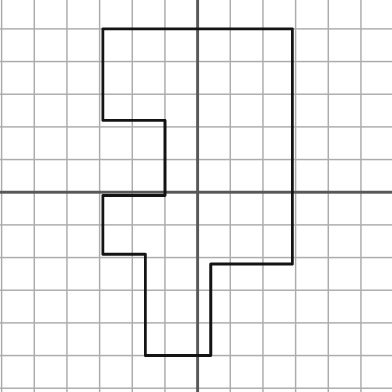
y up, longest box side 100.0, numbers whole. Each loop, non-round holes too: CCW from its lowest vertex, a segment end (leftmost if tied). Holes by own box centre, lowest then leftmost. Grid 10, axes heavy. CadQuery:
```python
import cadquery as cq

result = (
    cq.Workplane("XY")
    .moveTo(-16.0, -50.0)
    .lineTo(4.0, -50.0)
    .lineTo(4.0, -22.0)
    .lineTo(29.0, -22.0)
    .lineTo(29.0, 50.0)
    .lineTo(-29.0, 50.0)
    .lineTo(-29.0, 22.0)
    .lineTo(-10.0, 22.0)
    .lineTo(-10.0, -1.0)
    .lineTo(-29.0, -1.0)
    .lineTo(-29.0, -19.0)
    .lineTo(-16.0, -19.0)
    .close()
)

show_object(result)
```